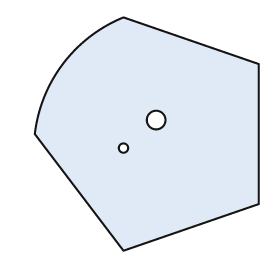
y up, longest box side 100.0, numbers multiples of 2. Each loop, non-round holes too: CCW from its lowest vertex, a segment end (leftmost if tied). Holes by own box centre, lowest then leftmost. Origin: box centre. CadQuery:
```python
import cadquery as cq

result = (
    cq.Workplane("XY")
    .moveTo(-10.0, -50.0)
    .lineTo(48.0, -30.0)
    .lineTo(48.0, 30.0)
    .lineTo(-10.0, 50.0)
    .threePointArc((-36.0, 30.0), (-48.0, 0.0))
    .close()
    .moveTo(-10.0, -6.0)
    .circle(2.0)
    .moveTo(4.0, 6.0)
    .circle(4.0)
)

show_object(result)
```